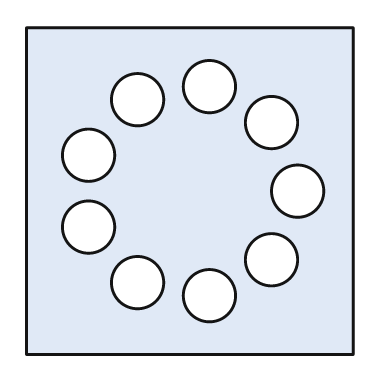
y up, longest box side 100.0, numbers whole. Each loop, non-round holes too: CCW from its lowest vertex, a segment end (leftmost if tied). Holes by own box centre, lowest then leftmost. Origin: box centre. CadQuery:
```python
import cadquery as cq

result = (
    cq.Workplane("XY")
    .moveTo(-50.0, -50.0)
    .lineTo(50.0, -50.0)
    .lineTo(50.0, 50.0)
    .lineTo(-50.0, 50.0)
    .close()
    .moveTo(6.0, -32.0)
    .circle(8.0)
    .moveTo(-16.0, -28.0)
    .circle(8.0)
    .moveTo(25.0, -21.0)
    .circle(8.0)
    .moveTo(-31.0, -11.0)
    .circle(8.0)
    .moveTo(33.0, 0.0)
    .circle(8.0)
    .moveTo(-31.0, 11.0)
    .circle(8.0)
    .moveTo(25.0, 21.0)
    .circle(8.0)
    .moveTo(-16.0, 28.0)
    .circle(8.0)
    .moveTo(6.0, 32.0)
    .circle(8.0)
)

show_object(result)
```